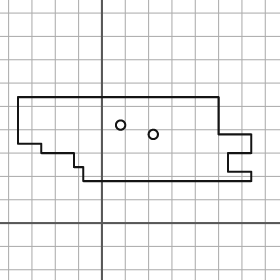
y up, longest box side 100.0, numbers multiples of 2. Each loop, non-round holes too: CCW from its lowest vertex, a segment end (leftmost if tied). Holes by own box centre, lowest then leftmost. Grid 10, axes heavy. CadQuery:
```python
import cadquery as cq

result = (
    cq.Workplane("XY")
    .moveTo(-8.0, 18.0)
    .lineTo(64.0, 18.0)
    .lineTo(64.0, 22.0)
    .lineTo(54.0, 22.0)
    .lineTo(54.0, 30.0)
    .lineTo(64.0, 30.0)
    .lineTo(64.0, 38.0)
    .lineTo(50.0, 38.0)
    .lineTo(50.0, 54.0)
    .lineTo(-36.0, 54.0)
    .lineTo(-36.0, 34.0)
    .lineTo(-26.0, 34.0)
    .lineTo(-26.0, 30.0)
    .lineTo(-12.0, 30.0)
    .lineTo(-12.0, 24.0)
    .lineTo(-8.0, 24.0)
    .close()
    .moveTo(22.0, 38.0)
    .circle(2.0)
    .moveTo(8.0, 42.0)
    .circle(2.0)
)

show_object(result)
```